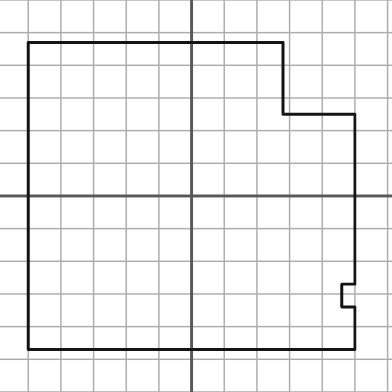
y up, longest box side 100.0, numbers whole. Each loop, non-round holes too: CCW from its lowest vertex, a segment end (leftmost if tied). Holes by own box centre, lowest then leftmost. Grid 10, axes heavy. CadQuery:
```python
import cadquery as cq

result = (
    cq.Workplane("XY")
    .moveTo(-50.0, -47.0)
    .lineTo(50.0, -47.0)
    .lineTo(50.0, -34.0)
    .lineTo(46.0, -34.0)
    .lineTo(46.0, -27.0)
    .lineTo(50.0, -27.0)
    .lineTo(50.0, 25.0)
    .lineTo(28.0, 25.0)
    .lineTo(28.0, 47.0)
    .lineTo(-50.0, 47.0)
    .close()
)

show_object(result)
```